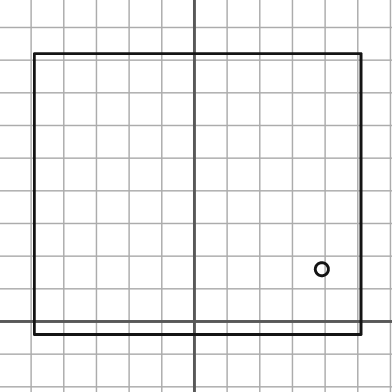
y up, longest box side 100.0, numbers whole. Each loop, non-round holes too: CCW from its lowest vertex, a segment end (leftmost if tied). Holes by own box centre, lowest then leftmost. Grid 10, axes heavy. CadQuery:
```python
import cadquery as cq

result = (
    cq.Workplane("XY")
    .moveTo(-49.0, -4.0)
    .lineTo(51.0, -4.0)
    .lineTo(51.0, 82.0)
    .lineTo(-49.0, 82.0)
    .close()
    .moveTo(39.0, 16.0)
    .circle(2.0)
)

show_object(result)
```